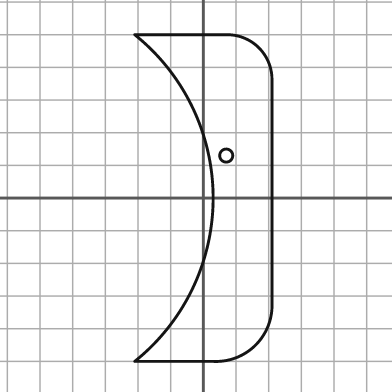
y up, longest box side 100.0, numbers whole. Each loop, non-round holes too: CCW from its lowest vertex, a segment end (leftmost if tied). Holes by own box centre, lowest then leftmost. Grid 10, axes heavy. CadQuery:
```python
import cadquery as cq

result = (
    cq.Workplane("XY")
    .moveTo(-21.0, -50.0)
    .lineTo(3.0, -50.0)
    .threePointArc((16.0, -45.0), (21.0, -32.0))
    .lineTo(21.0, 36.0)
    .threePointArc((17.0, 46.0), (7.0, 50.0))
    .lineTo(-21.0, 50.0)
    .threePointArc((3.0, 0.0), (-21.0, -50.0))
    .close()
    .moveTo(7.0, 13.0)
    .circle(2.0)
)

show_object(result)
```